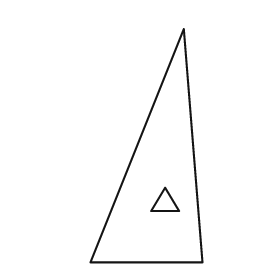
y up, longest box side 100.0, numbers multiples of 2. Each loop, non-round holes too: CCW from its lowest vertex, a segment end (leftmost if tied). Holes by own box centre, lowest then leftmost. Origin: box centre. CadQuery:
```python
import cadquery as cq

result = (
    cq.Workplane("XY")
    .moveTo(-24.0, -50.0)
    .lineTo(24.0, -50.0)
    .lineTo(16.0, 50.0)
    .close()
    .moveTo(2.0, -28.0)
    .lineTo(14.0, -28.0)
    .lineTo(8.0, -18.0)
    .close()
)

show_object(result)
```